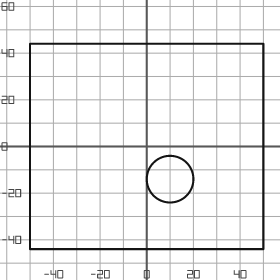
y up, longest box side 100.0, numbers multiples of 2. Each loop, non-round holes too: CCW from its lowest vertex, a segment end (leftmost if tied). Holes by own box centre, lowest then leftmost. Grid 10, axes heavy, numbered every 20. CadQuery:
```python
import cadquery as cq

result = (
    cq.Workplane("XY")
    .moveTo(-50.0, -44.0)
    .lineTo(50.0, -44.0)
    .lineTo(50.0, 44.0)
    .lineTo(-50.0, 44.0)
    .close()
    .moveTo(10.0, -14.0)
    .circle(10.0)
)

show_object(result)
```